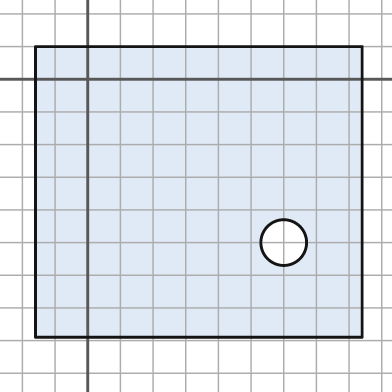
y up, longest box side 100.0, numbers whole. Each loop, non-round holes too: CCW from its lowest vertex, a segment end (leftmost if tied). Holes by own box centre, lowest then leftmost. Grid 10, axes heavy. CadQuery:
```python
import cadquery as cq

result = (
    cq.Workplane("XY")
    .moveTo(-16.0, -79.0)
    .lineTo(84.0, -79.0)
    .lineTo(84.0, 10.0)
    .lineTo(-16.0, 10.0)
    .close()
    .moveTo(60.0, -50.0)
    .circle(7.0)
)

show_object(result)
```